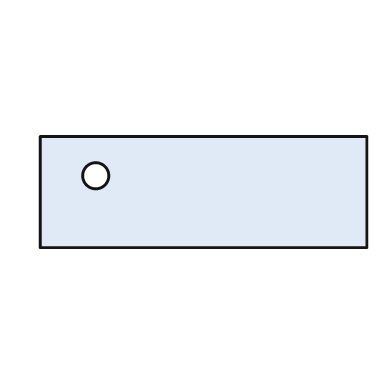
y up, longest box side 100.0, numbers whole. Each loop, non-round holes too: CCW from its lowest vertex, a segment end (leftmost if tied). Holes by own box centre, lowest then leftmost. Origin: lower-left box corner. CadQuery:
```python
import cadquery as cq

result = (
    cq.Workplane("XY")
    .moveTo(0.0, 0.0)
    .lineTo(100.0, 0.0)
    .lineTo(100.0, 34.0)
    .lineTo(0.0, 34.0)
    .close()
    .moveTo(17.0, 22.0)
    .circle(4.0)
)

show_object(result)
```